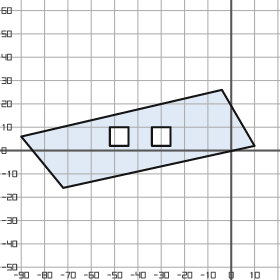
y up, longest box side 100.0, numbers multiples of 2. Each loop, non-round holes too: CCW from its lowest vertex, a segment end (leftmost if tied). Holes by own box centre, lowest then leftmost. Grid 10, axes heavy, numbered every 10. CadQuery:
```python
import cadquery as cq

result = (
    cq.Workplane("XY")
    .moveTo(-72.0, -16.0)
    .lineTo(10.0, 2.0)
    .lineTo(-4.0, 26.0)
    .lineTo(-90.0, 6.0)
    .close()
    .moveTo(-52.0, 2.0)
    .lineTo(-44.0, 2.0)
    .lineTo(-44.0, 10.0)
    .lineTo(-52.0, 10.0)
    .close()
    .moveTo(-34.0, 2.0)
    .lineTo(-26.0, 2.0)
    .lineTo(-26.0, 10.0)
    .lineTo(-34.0, 10.0)
    .close()
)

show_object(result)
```